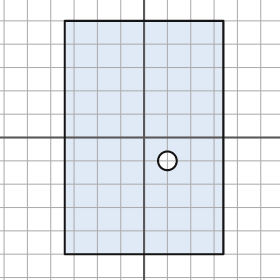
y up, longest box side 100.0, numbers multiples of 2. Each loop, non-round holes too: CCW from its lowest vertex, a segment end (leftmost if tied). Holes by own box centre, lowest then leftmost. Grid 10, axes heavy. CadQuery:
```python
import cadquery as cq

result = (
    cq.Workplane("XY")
    .moveTo(-34.0, -50.0)
    .lineTo(34.0, -50.0)
    .lineTo(34.0, 50.0)
    .lineTo(-34.0, 50.0)
    .close()
    .moveTo(10.0, -10.0)
    .circle(4.0)
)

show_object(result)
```